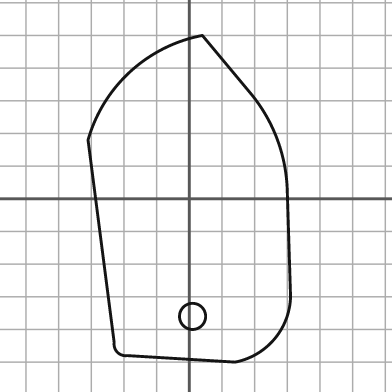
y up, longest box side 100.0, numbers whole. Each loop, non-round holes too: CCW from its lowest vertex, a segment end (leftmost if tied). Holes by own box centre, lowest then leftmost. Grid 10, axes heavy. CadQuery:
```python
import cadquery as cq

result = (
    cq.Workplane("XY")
    .moveTo(14.0, -50.0)
    .threePointArc((26.0, -43.0), (31.0, -30.0))
    .lineTo(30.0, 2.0)
    .threePointArc((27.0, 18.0), (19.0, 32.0))
    .lineTo(4.0, 50.0)
    .threePointArc((-18.0, 39.0), (-31.0, 18.0))
    .lineTo(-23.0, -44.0)
    .threePointArc((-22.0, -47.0), (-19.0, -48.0))
    .close()
    .moveTo(1.0, -36.0)
    .circle(4.0)
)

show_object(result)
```